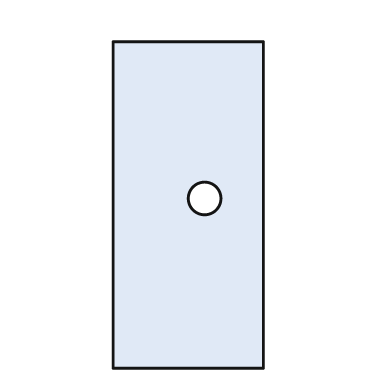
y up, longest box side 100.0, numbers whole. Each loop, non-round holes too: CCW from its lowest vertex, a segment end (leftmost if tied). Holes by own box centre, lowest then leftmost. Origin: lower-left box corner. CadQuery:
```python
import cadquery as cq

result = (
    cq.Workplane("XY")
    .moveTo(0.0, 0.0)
    .lineTo(46.0, 0.0)
    .lineTo(46.0, 100.0)
    .lineTo(0.0, 100.0)
    .close()
    .moveTo(28.0, 52.0)
    .circle(5.0)
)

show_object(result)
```